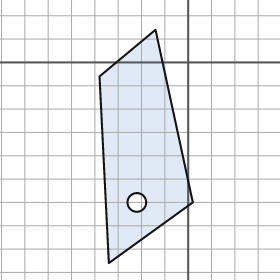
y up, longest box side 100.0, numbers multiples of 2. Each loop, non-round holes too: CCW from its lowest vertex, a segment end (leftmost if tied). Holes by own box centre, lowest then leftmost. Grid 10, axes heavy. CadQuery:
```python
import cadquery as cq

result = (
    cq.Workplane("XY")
    .moveTo(-34.0, -86.0)
    .lineTo(2.0, -60.0)
    .lineTo(-14.0, 14.0)
    .lineTo(-38.0, -6.0)
    .close()
    .moveTo(-22.0, -60.0)
    .circle(4.0)
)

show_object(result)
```